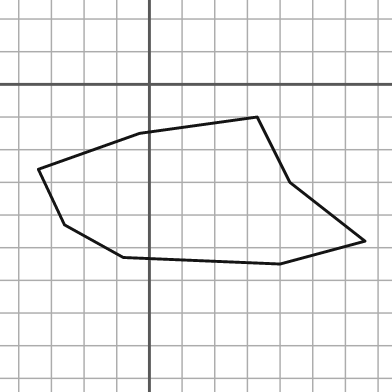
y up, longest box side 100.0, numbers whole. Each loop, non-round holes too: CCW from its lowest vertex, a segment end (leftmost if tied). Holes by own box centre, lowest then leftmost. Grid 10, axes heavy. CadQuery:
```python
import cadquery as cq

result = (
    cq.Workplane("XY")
    .moveTo(40.0, -55.0)
    .lineTo(66.0, -48.0)
    .lineTo(43.0, -30.0)
    .lineTo(33.0, -10.0)
    .lineTo(-3.0, -15.0)
    .lineTo(-34.0, -26.0)
    .lineTo(-26.0, -43.0)
    .lineTo(-8.0, -53.0)
    .close()
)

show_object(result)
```